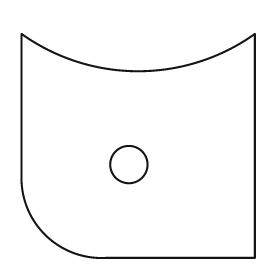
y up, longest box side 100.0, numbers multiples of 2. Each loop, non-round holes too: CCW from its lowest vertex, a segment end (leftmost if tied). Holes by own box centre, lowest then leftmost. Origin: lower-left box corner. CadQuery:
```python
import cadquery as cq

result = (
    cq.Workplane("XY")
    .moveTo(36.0, 0.0)
    .lineTo(100.0, 0.0)
    .lineTo(100.0, 96.0)
    .threePointArc((50.0, 80.0), (0.0, 96.0))
    .lineTo(0.0, 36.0)
    .threePointArc((10.0, 10.0), (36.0, 0.0))
    .close()
    .moveTo(46.0, 40.0)
    .circle(8.0)
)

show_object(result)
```